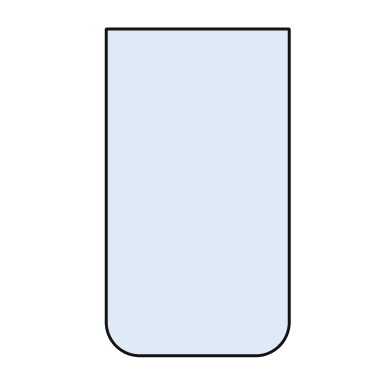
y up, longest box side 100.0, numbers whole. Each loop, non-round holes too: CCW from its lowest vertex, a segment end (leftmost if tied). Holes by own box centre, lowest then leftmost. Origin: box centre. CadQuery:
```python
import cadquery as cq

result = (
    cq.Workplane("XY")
    .moveTo(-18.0, -50.0)
    .lineTo(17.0, -50.0)
    .threePointArc((25.0, -47.0), (28.0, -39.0))
    .lineTo(28.0, 50.0)
    .lineTo(-28.0, 50.0)
    .lineTo(-28.0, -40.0)
    .threePointArc((-25.0, -47.0), (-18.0, -50.0))
    .close()
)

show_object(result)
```